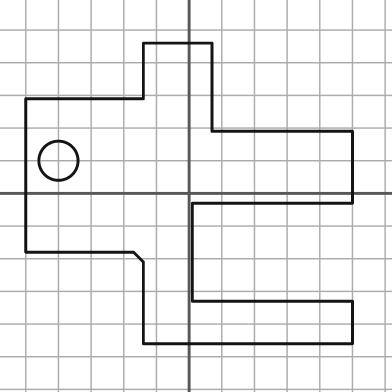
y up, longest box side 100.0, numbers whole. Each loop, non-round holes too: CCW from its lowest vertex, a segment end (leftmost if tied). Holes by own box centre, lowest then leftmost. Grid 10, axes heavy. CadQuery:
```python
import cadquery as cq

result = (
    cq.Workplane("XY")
    .moveTo(-14.0, -46.0)
    .lineTo(50.0, -46.0)
    .lineTo(50.0, -33.0)
    .lineTo(1.0, -33.0)
    .lineTo(1.0, -3.0)
    .lineTo(50.0, -3.0)
    .lineTo(50.0, 19.0)
    .lineTo(7.0, 19.0)
    .lineTo(7.0, 46.0)
    .lineTo(-14.0, 46.0)
    .lineTo(-14.0, 29.0)
    .lineTo(-50.0, 29.0)
    .lineTo(-50.0, -18.0)
    .lineTo(-17.0, -18.0)
    .lineTo(-14.0, -21.0)
    .close()
    .moveTo(-40.0, 10.0)
    .circle(6.0)
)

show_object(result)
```